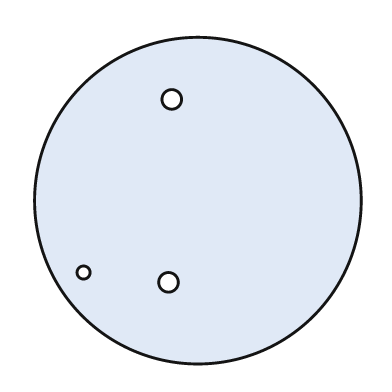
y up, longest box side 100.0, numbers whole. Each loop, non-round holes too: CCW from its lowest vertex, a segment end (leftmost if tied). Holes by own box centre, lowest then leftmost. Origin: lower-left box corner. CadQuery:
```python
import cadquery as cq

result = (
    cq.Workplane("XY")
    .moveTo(50.0, 50.0)
    .circle(50.0)
    .moveTo(41.0, 25.0)
    .circle(3.0)
    .moveTo(15.0, 28.0)
    .circle(2.0)
    .moveTo(42.0, 81.0)
    .circle(3.0)
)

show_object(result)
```